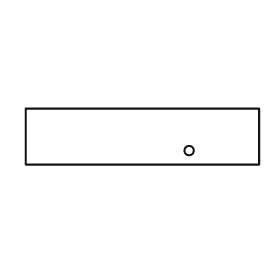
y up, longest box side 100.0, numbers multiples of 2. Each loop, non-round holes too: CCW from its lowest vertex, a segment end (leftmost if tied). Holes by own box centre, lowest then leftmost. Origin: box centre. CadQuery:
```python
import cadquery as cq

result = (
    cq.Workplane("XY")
    .moveTo(-50.0, -12.0)
    .lineTo(50.0, -12.0)
    .lineTo(50.0, 12.0)
    .lineTo(-50.0, 12.0)
    .close()
    .moveTo(20.0, -6.0)
    .circle(2.0)
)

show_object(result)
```